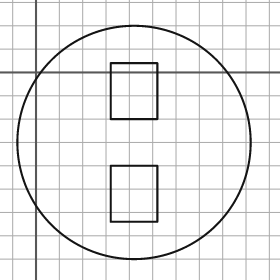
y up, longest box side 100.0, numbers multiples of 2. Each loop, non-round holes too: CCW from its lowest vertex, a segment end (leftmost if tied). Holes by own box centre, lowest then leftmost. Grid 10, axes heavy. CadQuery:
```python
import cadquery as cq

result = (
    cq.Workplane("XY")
    .moveTo(42.0, -30.0)
    .circle(50.0)
    .moveTo(32.0, -64.0)
    .lineTo(52.0, -64.0)
    .lineTo(52.0, -40.0)
    .lineTo(32.0, -40.0)
    .close()
    .moveTo(32.0, -20.0)
    .lineTo(52.0, -20.0)
    .lineTo(52.0, 4.0)
    .lineTo(32.0, 4.0)
    .close()
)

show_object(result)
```